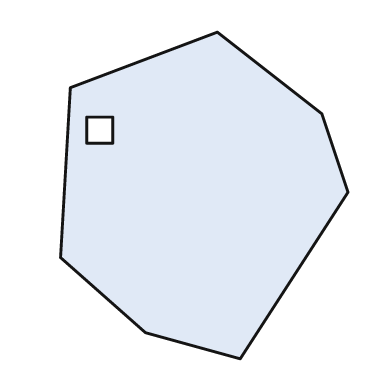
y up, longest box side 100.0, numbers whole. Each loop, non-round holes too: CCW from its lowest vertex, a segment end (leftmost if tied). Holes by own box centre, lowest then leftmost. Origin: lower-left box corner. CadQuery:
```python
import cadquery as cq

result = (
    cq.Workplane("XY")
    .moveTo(55.0, 0.0)
    .lineTo(88.0, 51.0)
    .lineTo(80.0, 75.0)
    .lineTo(48.0, 100.0)
    .lineTo(3.0, 83.0)
    .lineTo(0.0, 31.0)
    .lineTo(26.0, 8.0)
    .close()
    .moveTo(8.0, 66.0)
    .lineTo(16.0, 66.0)
    .lineTo(16.0, 74.0)
    .lineTo(8.0, 74.0)
    .close()
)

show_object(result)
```